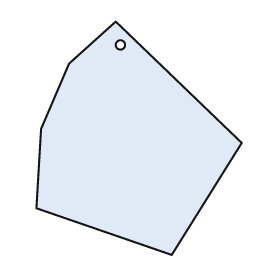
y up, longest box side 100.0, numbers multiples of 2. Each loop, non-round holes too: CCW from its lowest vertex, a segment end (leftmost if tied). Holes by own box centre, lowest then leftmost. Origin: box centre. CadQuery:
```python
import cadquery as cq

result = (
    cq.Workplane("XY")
    .moveTo(14.0, -50.0)
    .lineTo(44.0, -2.0)
    .lineTo(-10.0, 50.0)
    .lineTo(-30.0, 32.0)
    .lineTo(-42.0, 4.0)
    .lineTo(-44.0, -30.0)
    .close()
    .moveTo(-8.0, 40.0)
    .circle(2.0)
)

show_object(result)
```